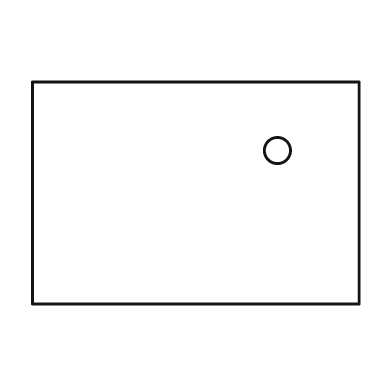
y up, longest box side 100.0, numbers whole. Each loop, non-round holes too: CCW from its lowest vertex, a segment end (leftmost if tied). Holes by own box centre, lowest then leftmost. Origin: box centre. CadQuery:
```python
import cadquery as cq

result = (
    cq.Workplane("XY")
    .moveTo(-50.0, -34.0)
    .lineTo(50.0, -34.0)
    .lineTo(50.0, 34.0)
    .lineTo(-50.0, 34.0)
    .close()
    .moveTo(25.0, 13.0)
    .circle(4.0)
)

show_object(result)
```